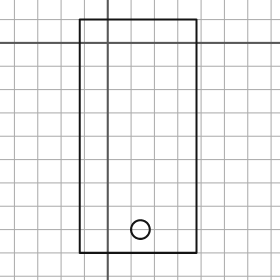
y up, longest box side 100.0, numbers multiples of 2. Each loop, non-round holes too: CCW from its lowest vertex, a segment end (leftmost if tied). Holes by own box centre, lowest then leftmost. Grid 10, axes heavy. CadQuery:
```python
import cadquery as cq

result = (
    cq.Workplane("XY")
    .moveTo(-12.0, -90.0)
    .lineTo(38.0, -90.0)
    .lineTo(38.0, 10.0)
    .lineTo(-12.0, 10.0)
    .close()
    .moveTo(14.0, -80.0)
    .circle(4.0)
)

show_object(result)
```